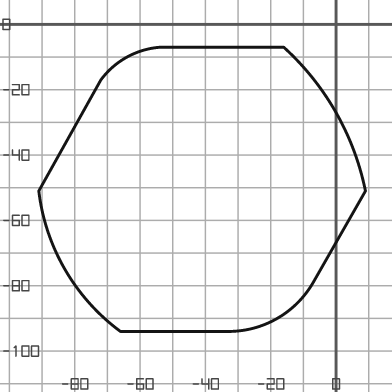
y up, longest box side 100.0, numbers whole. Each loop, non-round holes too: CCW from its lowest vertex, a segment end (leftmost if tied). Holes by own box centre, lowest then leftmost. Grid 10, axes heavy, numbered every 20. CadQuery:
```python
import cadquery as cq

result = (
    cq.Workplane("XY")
    .moveTo(-66.0, -94.0)
    .lineTo(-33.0, -94.0)
    .threePointArc((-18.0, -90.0), (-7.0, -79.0))
    .lineTo(9.0, -51.0)
    .threePointArc((0.0, -27.0), (-16.0, -7.0))
    .lineTo(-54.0, -7.0)
    .threePointArc((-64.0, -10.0), (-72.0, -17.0))
    .lineTo(-91.0, -51.0)
    .threePointArc((-83.0, -75.0), (-66.0, -94.0))
    .close()
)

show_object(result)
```